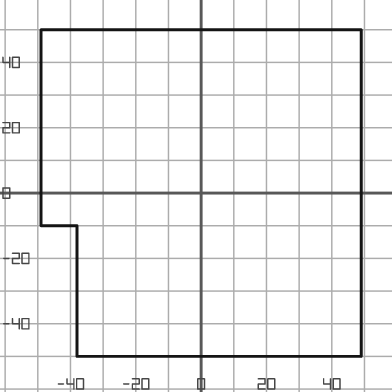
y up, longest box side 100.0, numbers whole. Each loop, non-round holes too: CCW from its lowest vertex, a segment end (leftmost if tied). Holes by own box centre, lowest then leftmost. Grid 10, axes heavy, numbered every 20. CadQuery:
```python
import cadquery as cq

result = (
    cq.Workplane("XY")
    .moveTo(-38.0, -50.0)
    .lineTo(49.0, -50.0)
    .lineTo(49.0, 50.0)
    .lineTo(-49.0, 50.0)
    .lineTo(-49.0, -10.0)
    .lineTo(-38.0, -10.0)
    .close()
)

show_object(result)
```